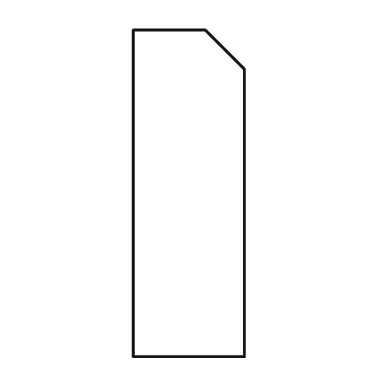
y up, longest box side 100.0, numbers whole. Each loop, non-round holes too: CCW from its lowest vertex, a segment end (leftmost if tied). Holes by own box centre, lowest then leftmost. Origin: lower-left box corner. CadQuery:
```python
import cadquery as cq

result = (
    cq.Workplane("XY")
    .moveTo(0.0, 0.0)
    .lineTo(34.0, 0.0)
    .lineTo(34.0, 88.0)
    .lineTo(22.0, 100.0)
    .lineTo(0.0, 100.0)
    .close()
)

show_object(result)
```